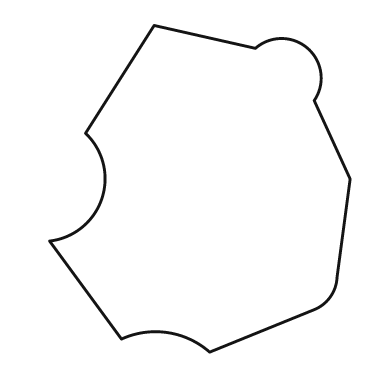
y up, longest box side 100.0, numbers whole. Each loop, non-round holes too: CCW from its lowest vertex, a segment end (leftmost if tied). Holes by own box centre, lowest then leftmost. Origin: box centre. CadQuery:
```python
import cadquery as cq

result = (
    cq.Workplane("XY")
    .moveTo(3.0, -50.0)
    .lineTo(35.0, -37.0)
    .threePointArc((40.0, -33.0), (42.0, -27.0))
    .lineTo(46.0, 3.0)
    .lineTo(35.0, 27.0)
    .threePointArc((33.0, 43.0), (17.0, 43.0))
    .lineTo(-14.0, 50.0)
    .lineTo(-35.0, 17.0)
    .threePointArc((-30.0, -3.0), (-46.0, -16.0))
    .lineTo(-24.0, -46.0)
    .threePointArc((-10.0, -44.0), (3.0, -50.0))
    .close()
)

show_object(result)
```